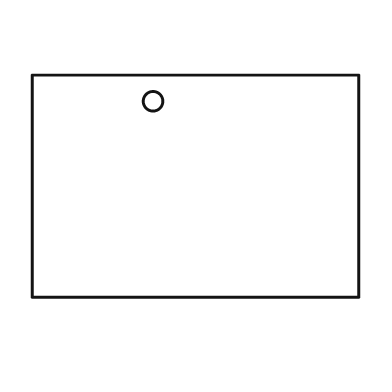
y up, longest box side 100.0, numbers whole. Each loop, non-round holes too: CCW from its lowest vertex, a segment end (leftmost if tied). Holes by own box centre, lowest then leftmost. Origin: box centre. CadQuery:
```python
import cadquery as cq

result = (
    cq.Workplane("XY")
    .moveTo(-50.0, -34.0)
    .lineTo(50.0, -34.0)
    .lineTo(50.0, 34.0)
    .lineTo(-50.0, 34.0)
    .close()
    .moveTo(-13.0, 26.0)
    .circle(3.0)
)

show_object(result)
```